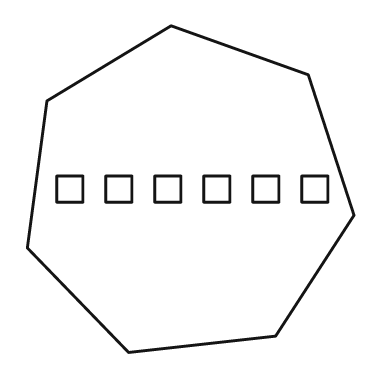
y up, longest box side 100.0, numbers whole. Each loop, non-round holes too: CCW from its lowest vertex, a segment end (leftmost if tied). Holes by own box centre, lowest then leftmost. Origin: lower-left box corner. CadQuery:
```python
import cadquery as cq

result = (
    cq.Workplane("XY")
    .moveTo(31.0, 0.0)
    .lineTo(76.0, 5.0)
    .lineTo(100.0, 42.0)
    .lineTo(86.0, 85.0)
    .lineTo(44.0, 100.0)
    .lineTo(6.0, 77.0)
    .lineTo(0.0, 32.0)
    .close()
    .moveTo(9.0, 46.0)
    .lineTo(17.0, 46.0)
    .lineTo(17.0, 54.0)
    .lineTo(9.0, 54.0)
    .close()
    .moveTo(24.0, 46.0)
    .lineTo(32.0, 46.0)
    .lineTo(32.0, 54.0)
    .lineTo(24.0, 54.0)
    .close()
    .moveTo(39.0, 46.0)
    .lineTo(47.0, 46.0)
    .lineTo(47.0, 54.0)
    .lineTo(39.0, 54.0)
    .close()
    .moveTo(54.0, 46.0)
    .lineTo(62.0, 46.0)
    .lineTo(62.0, 54.0)
    .lineTo(54.0, 54.0)
    .close()
    .moveTo(69.0, 46.0)
    .lineTo(77.0, 46.0)
    .lineTo(77.0, 54.0)
    .lineTo(69.0, 54.0)
    .close()
    .moveTo(84.0, 46.0)
    .lineTo(92.0, 46.0)
    .lineTo(92.0, 54.0)
    .lineTo(84.0, 54.0)
    .close()
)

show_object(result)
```